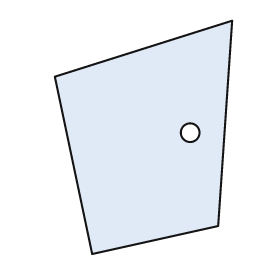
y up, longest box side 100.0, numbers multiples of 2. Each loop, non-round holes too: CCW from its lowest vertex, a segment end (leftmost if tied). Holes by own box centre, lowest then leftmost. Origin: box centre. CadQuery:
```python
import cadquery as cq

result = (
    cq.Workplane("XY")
    .moveTo(-22.0, -50.0)
    .lineTo(32.0, -38.0)
    .lineTo(38.0, 50.0)
    .lineTo(-38.0, 26.0)
    .close()
    .moveTo(20.0, 2.0)
    .circle(4.0)
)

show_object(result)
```